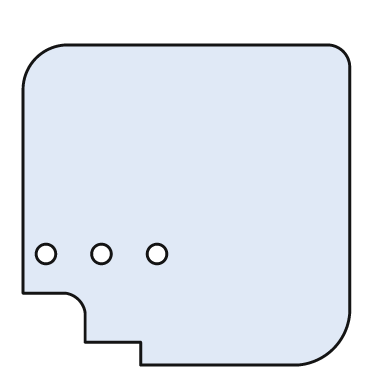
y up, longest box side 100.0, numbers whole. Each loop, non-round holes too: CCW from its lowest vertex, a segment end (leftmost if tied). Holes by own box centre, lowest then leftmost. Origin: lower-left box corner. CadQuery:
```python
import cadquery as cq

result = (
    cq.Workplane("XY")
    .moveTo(36.0, 0.0)
    .lineTo(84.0, 0.0)
    .threePointArc((95.0, 5.0), (100.0, 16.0))
    .lineTo(100.0, 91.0)
    .threePointArc((98.0, 96.0), (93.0, 98.0))
    .lineTo(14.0, 98.0)
    .threePointArc((4.0, 94.0), (0.0, 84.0))
    .lineTo(0.0, 22.0)
    .lineTo(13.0, 22.0)
    .threePointArc((17.0, 20.0), (19.0, 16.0))
    .lineTo(19.0, 7.0)
    .lineTo(36.0, 7.0)
    .close()
    .moveTo(7.0, 34.0)
    .circle(3.0)
    .moveTo(24.0, 34.0)
    .circle(3.0)
    .moveTo(41.0, 34.0)
    .circle(3.0)
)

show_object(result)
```